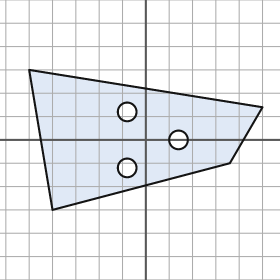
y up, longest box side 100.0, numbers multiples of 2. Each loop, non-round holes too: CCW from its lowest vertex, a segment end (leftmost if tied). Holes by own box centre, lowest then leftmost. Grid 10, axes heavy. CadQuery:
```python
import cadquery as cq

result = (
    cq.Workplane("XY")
    .moveTo(-40.0, -30.0)
    .lineTo(36.0, -10.0)
    .lineTo(50.0, 14.0)
    .lineTo(-50.0, 30.0)
    .close()
    .moveTo(-8.0, -12.0)
    .circle(4.0)
    .moveTo(14.0, 0.0)
    .circle(4.0)
    .moveTo(-8.0, 12.0)
    .circle(4.0)
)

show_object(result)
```